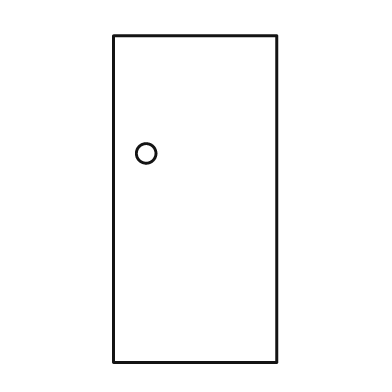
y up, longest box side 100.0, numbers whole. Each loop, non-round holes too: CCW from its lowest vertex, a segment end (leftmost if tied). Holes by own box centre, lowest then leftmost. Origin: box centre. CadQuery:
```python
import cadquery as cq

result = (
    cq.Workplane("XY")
    .moveTo(-25.0, -50.0)
    .lineTo(25.0, -50.0)
    .lineTo(25.0, 50.0)
    .lineTo(-25.0, 50.0)
    .close()
    .moveTo(-15.0, 14.0)
    .circle(3.0)
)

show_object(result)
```